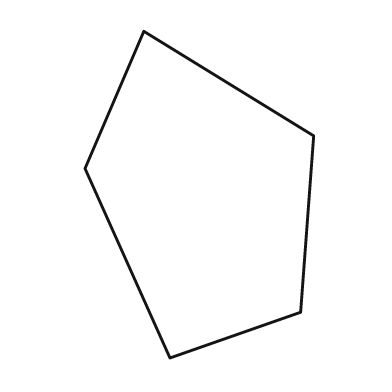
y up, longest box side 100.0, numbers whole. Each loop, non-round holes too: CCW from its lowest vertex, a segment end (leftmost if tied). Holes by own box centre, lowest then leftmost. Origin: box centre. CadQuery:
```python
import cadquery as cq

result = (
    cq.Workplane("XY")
    .moveTo(-9.0, -50.0)
    .lineTo(31.0, -36.0)
    .lineTo(35.0, 18.0)
    .lineTo(-17.0, 50.0)
    .lineTo(-35.0, 8.0)
    .close()
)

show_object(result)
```